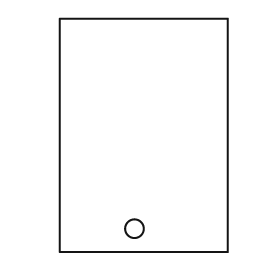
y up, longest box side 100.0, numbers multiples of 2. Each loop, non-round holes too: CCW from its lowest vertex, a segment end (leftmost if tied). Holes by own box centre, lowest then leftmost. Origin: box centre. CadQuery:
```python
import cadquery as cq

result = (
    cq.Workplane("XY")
    .moveTo(-36.0, -50.0)
    .lineTo(36.0, -50.0)
    .lineTo(36.0, 50.0)
    .lineTo(-36.0, 50.0)
    .close()
    .moveTo(-4.0, -40.0)
    .circle(4.0)
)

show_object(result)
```